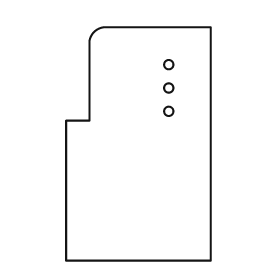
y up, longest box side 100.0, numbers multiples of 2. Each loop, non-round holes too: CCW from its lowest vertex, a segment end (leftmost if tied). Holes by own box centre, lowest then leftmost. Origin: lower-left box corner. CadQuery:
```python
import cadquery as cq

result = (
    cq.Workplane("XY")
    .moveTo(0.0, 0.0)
    .lineTo(62.0, 0.0)
    .lineTo(62.0, 100.0)
    .lineTo(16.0, 100.0)
    .threePointArc((12.0, 98.0), (10.0, 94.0))
    .lineTo(10.0, 60.0)
    .lineTo(0.0, 60.0)
    .close()
    .moveTo(44.0, 64.0)
    .circle(2.0)
    .moveTo(44.0, 74.0)
    .circle(2.0)
    .moveTo(44.0, 84.0)
    .circle(2.0)
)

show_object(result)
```